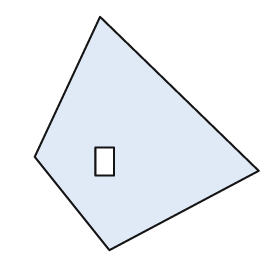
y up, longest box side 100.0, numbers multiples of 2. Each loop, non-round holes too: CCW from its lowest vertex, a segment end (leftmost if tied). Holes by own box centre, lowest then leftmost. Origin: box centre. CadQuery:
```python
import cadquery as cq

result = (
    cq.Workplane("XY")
    .moveTo(-16.0, -50.0)
    .lineTo(48.0, -16.0)
    .lineTo(-20.0, 50.0)
    .lineTo(-48.0, -10.0)
    .close()
    .moveTo(-22.0, -18.0)
    .lineTo(-14.0, -18.0)
    .lineTo(-14.0, -6.0)
    .lineTo(-22.0, -6.0)
    .close()
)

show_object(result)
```